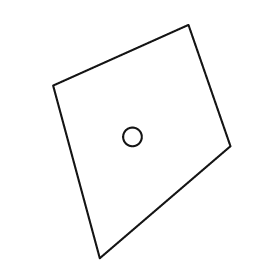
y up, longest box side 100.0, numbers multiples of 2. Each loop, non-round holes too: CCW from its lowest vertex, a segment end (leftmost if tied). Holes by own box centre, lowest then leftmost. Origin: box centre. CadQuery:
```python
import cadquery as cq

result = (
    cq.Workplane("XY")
    .moveTo(-18.0, -50.0)
    .lineTo(38.0, -2.0)
    .lineTo(20.0, 50.0)
    .lineTo(-38.0, 24.0)
    .close()
    .moveTo(-4.0, 2.0)
    .circle(4.0)
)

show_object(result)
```